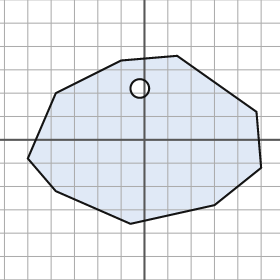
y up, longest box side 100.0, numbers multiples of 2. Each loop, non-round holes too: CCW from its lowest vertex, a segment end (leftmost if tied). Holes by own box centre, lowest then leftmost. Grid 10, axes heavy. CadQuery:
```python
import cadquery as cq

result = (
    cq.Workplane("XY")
    .moveTo(-6.0, -36.0)
    .lineTo(30.0, -28.0)
    .lineTo(50.0, -12.0)
    .lineTo(48.0, 12.0)
    .lineTo(14.0, 36.0)
    .lineTo(-10.0, 34.0)
    .lineTo(-38.0, 20.0)
    .lineTo(-50.0, -8.0)
    .lineTo(-38.0, -22.0)
    .close()
    .moveTo(-2.0, 22.0)
    .circle(4.0)
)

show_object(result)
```